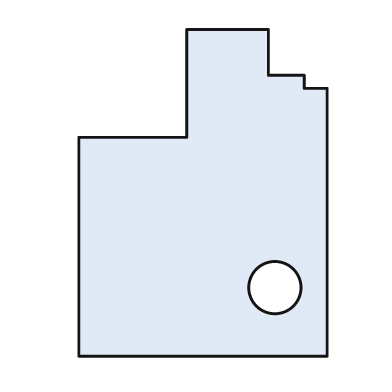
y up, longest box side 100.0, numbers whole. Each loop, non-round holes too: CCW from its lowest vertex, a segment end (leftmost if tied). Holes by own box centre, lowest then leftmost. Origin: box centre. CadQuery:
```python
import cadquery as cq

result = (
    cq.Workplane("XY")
    .moveTo(-38.0, -50.0)
    .lineTo(38.0, -50.0)
    .lineTo(38.0, 32.0)
    .lineTo(31.0, 32.0)
    .lineTo(31.0, 36.0)
    .lineTo(20.0, 36.0)
    .lineTo(20.0, 50.0)
    .lineTo(-5.0, 50.0)
    .lineTo(-5.0, 17.0)
    .lineTo(-38.0, 17.0)
    .close()
    .moveTo(22.0, -29.0)
    .circle(8.0)
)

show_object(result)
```